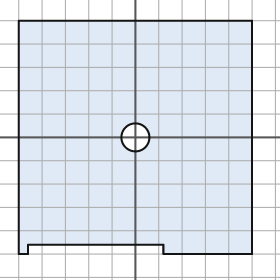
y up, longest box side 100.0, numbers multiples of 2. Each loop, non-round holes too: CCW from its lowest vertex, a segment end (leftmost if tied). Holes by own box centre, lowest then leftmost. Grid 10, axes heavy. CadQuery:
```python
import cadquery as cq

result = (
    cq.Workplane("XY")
    .moveTo(-50.0, -50.0)
    .lineTo(-46.0, -50.0)
    .lineTo(-46.0, -46.0)
    .lineTo(12.0, -46.0)
    .lineTo(12.0, -50.0)
    .lineTo(50.0, -50.0)
    .lineTo(50.0, 50.0)
    .lineTo(-50.0, 50.0)
    .close()
    .moveTo(0.0, 0.0)
    .circle(6.0)
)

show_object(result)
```